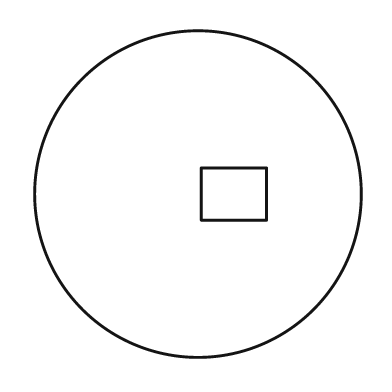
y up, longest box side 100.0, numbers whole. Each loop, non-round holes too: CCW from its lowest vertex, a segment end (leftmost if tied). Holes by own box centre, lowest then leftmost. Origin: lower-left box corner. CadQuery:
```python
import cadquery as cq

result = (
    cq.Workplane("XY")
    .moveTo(50.0, 50.0)
    .circle(50.0)
    .moveTo(51.0, 42.0)
    .lineTo(71.0, 42.0)
    .lineTo(71.0, 58.0)
    .lineTo(51.0, 58.0)
    .close()
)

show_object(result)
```